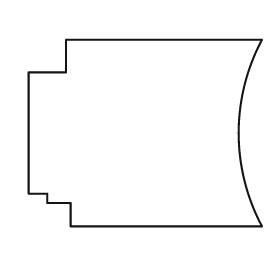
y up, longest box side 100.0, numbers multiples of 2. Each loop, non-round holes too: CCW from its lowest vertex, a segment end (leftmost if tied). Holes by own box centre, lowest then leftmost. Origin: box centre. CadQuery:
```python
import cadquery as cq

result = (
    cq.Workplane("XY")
    .moveTo(-32.0, -40.0)
    .lineTo(50.0, -40.0)
    .threePointArc((40.0, 0.0), (50.0, 40.0))
    .lineTo(-34.0, 40.0)
    .lineTo(-34.0, 26.0)
    .lineTo(-50.0, 26.0)
    .lineTo(-50.0, -26.0)
    .lineTo(-42.0, -26.0)
    .lineTo(-42.0, -30.0)
    .lineTo(-32.0, -30.0)
    .close()
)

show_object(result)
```